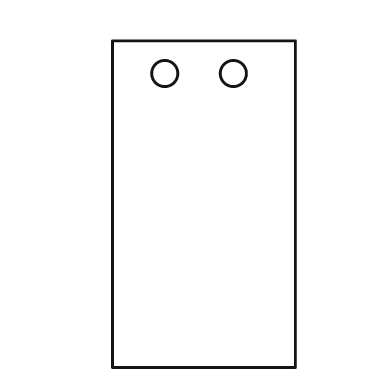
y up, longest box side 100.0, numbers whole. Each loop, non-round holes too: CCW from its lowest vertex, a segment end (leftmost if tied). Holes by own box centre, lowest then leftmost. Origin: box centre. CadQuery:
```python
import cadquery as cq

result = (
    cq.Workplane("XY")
    .moveTo(-28.0, -50.0)
    .lineTo(28.0, -50.0)
    .lineTo(28.0, 50.0)
    .lineTo(-28.0, 50.0)
    .close()
    .moveTo(-12.0, 40.0)
    .circle(4.0)
    .moveTo(9.0, 40.0)
    .circle(4.0)
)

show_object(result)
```